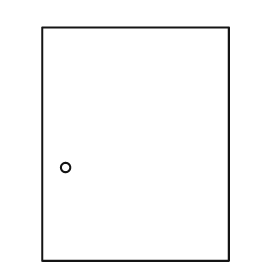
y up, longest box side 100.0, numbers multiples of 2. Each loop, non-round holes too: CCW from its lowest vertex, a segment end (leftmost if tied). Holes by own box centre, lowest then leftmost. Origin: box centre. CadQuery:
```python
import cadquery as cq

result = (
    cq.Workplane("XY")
    .moveTo(-40.0, -50.0)
    .lineTo(40.0, -50.0)
    .lineTo(40.0, 50.0)
    .lineTo(-40.0, 50.0)
    .close()
    .moveTo(-30.0, -10.0)
    .circle(2.0)
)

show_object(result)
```